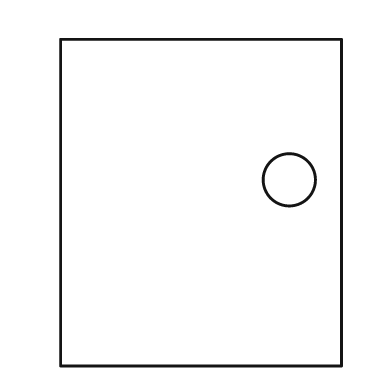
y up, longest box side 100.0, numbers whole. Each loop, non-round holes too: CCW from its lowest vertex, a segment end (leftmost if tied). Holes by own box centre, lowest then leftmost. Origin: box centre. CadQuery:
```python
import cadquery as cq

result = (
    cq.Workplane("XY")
    .moveTo(-43.0, -50.0)
    .lineTo(43.0, -50.0)
    .lineTo(43.0, 50.0)
    .lineTo(-43.0, 50.0)
    .close()
    .moveTo(27.0, 7.0)
    .circle(8.0)
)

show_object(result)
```